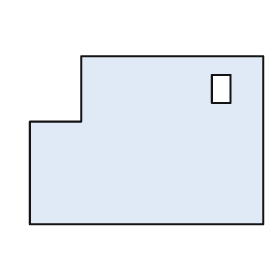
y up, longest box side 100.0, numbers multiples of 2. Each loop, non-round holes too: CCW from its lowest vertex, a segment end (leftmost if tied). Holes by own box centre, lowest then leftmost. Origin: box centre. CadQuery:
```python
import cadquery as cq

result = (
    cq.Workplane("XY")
    .moveTo(-50.0, -36.0)
    .lineTo(50.0, -36.0)
    .lineTo(50.0, 36.0)
    .lineTo(-28.0, 36.0)
    .lineTo(-28.0, 8.0)
    .lineTo(-50.0, 8.0)
    .close()
    .moveTo(28.0, 16.0)
    .lineTo(36.0, 16.0)
    .lineTo(36.0, 28.0)
    .lineTo(28.0, 28.0)
    .close()
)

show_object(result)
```